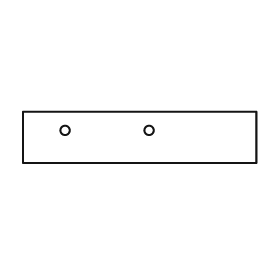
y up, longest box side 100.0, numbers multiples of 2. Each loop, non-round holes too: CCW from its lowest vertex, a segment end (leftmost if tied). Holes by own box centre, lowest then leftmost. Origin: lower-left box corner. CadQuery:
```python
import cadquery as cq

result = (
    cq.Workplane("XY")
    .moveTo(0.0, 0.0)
    .lineTo(100.0, 0.0)
    .lineTo(100.0, 22.0)
    .lineTo(0.0, 22.0)
    .close()
    .moveTo(18.0, 14.0)
    .circle(2.0)
    .moveTo(54.0, 14.0)
    .circle(2.0)
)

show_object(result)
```